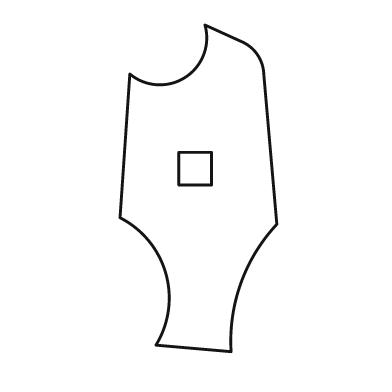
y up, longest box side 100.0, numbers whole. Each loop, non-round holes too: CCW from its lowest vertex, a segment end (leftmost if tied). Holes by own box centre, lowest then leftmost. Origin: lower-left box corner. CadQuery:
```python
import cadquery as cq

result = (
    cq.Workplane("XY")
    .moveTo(34.0, 0.0)
    .threePointArc((37.0, 21.0), (48.0, 39.0))
    .lineTo(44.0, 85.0)
    .threePointArc((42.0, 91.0), (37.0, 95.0))
    .lineTo(26.0, 100.0)
    .threePointArc((20.0, 84.0), (3.0, 85.0))
    .lineTo(0.0, 41.0)
    .threePointArc((14.0, 24.0), (11.0, 2.0))
    .close()
    .moveTo(18.0, 51.0)
    .lineTo(28.0, 51.0)
    .lineTo(28.0, 61.0)
    .lineTo(18.0, 61.0)
    .close()
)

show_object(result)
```